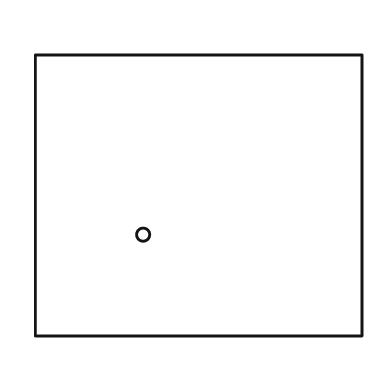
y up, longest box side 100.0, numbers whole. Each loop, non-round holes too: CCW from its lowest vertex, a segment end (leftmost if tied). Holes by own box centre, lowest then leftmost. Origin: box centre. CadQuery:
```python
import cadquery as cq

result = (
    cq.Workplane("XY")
    .moveTo(-50.0, -43.0)
    .lineTo(50.0, -43.0)
    .lineTo(50.0, 43.0)
    .lineTo(-50.0, 43.0)
    .close()
    .moveTo(-17.0, -12.0)
    .circle(2.0)
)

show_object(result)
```